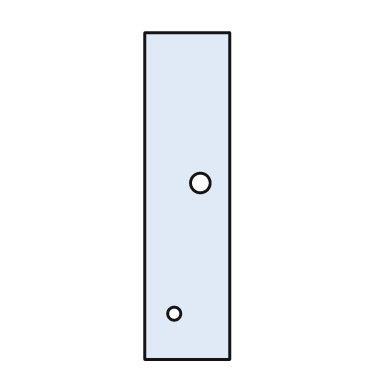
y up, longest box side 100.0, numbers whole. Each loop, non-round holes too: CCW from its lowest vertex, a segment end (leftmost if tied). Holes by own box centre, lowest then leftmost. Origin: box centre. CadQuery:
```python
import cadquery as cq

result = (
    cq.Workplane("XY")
    .moveTo(-13.0, -50.0)
    .lineTo(13.0, -50.0)
    .lineTo(13.0, 50.0)
    .lineTo(-13.0, 50.0)
    .close()
    .moveTo(-4.0, -36.0)
    .circle(2.0)
    .moveTo(4.0, 4.0)
    .circle(3.0)
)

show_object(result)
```